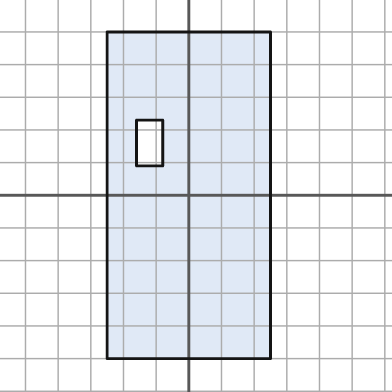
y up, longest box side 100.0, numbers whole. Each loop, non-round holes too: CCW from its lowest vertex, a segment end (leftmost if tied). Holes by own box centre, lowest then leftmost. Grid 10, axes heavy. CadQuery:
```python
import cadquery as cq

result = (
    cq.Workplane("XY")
    .moveTo(-25.0, -50.0)
    .lineTo(25.0, -50.0)
    .lineTo(25.0, 50.0)
    .lineTo(-25.0, 50.0)
    .close()
    .moveTo(-16.0, 9.0)
    .lineTo(-8.0, 9.0)
    .lineTo(-8.0, 23.0)
    .lineTo(-16.0, 23.0)
    .close()
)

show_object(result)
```